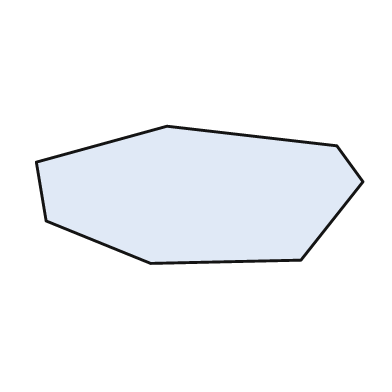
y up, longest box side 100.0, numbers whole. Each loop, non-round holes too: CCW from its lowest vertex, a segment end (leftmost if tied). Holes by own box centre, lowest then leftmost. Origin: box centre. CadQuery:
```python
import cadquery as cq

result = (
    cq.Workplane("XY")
    .moveTo(-15.0, -21.0)
    .lineTo(31.0, -20.0)
    .lineTo(50.0, 4.0)
    .lineTo(42.0, 15.0)
    .lineTo(-10.0, 21.0)
    .lineTo(-50.0, 10.0)
    .lineTo(-47.0, -8.0)
    .close()
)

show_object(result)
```